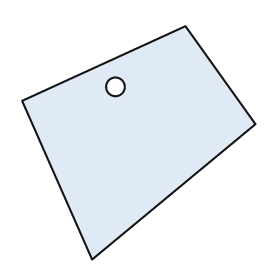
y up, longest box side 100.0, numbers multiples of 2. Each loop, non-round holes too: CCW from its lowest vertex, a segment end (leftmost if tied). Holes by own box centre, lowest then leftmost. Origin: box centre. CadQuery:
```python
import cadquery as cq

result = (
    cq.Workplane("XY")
    .moveTo(-20.0, -50.0)
    .lineTo(50.0, 8.0)
    .lineTo(20.0, 50.0)
    .lineTo(-50.0, 18.0)
    .close()
    .moveTo(-10.0, 24.0)
    .circle(4.0)
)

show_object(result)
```